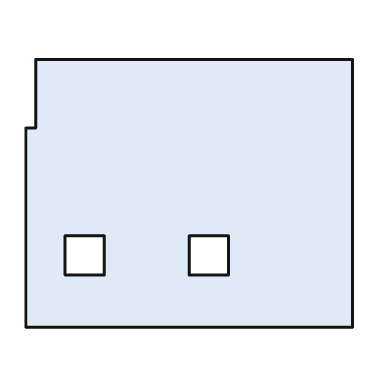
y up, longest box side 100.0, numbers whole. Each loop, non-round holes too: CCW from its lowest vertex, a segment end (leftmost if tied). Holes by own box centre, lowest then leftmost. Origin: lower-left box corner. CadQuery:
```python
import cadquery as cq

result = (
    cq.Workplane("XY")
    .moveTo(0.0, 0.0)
    .lineTo(100.0, 0.0)
    .lineTo(100.0, 82.0)
    .lineTo(3.0, 82.0)
    .lineTo(3.0, 61.0)
    .lineTo(0.0, 61.0)
    .close()
    .moveTo(12.0, 16.0)
    .lineTo(24.0, 16.0)
    .lineTo(24.0, 28.0)
    .lineTo(12.0, 28.0)
    .close()
    .moveTo(50.0, 16.0)
    .lineTo(62.0, 16.0)
    .lineTo(62.0, 28.0)
    .lineTo(50.0, 28.0)
    .close()
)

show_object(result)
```